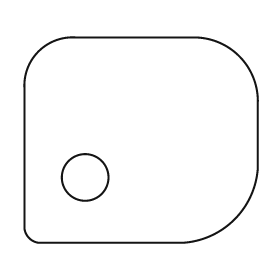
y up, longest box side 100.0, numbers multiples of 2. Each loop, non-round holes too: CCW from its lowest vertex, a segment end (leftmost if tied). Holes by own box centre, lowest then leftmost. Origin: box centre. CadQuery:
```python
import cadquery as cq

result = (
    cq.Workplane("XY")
    .moveTo(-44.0, -44.0)
    .lineTo(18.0, -44.0)
    .threePointArc((40.0, -34.0), (50.0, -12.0))
    .lineTo(50.0, 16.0)
    .threePointArc((42.0, 36.0), (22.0, 44.0))
    .lineTo(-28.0, 44.0)
    .threePointArc((-44.0, 38.0), (-50.0, 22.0))
    .lineTo(-50.0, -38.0)
    .threePointArc((-48.0, -42.0), (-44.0, -44.0))
    .close()
    .moveTo(-24.0, -16.0)
    .circle(10.0)
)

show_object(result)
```